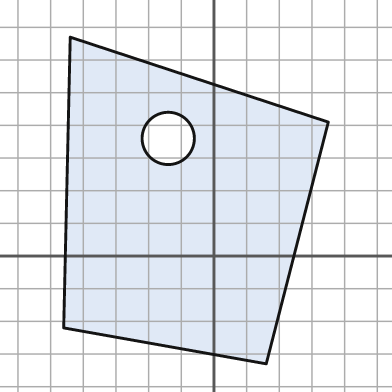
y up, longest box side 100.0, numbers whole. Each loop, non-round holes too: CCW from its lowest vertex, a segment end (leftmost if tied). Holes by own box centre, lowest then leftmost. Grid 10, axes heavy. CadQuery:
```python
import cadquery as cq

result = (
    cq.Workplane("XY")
    .moveTo(16.0, -33.0)
    .lineTo(35.0, 41.0)
    .lineTo(-44.0, 67.0)
    .lineTo(-46.0, -22.0)
    .close()
    .moveTo(-14.0, 36.0)
    .circle(8.0)
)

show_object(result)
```